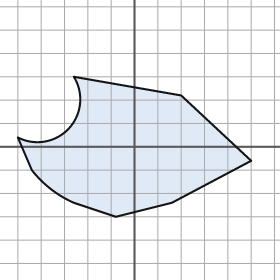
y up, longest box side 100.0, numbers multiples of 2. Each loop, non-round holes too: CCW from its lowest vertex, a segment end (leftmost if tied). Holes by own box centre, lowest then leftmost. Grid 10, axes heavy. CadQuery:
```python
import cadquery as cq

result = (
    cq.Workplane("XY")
    .moveTo(-8.0, -30.0)
    .lineTo(16.0, -24.0)
    .lineTo(50.0, -6.0)
    .lineTo(20.0, 22.0)
    .lineTo(-26.0, 30.0)
    .threePointArc((-28.0, 8.0), (-50.0, 4.0))
    .lineTo(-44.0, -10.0)
    .threePointArc((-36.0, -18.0), (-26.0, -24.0))
    .close()
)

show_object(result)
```